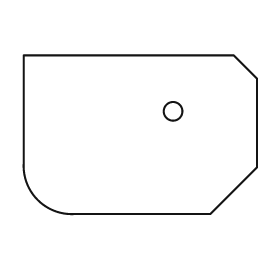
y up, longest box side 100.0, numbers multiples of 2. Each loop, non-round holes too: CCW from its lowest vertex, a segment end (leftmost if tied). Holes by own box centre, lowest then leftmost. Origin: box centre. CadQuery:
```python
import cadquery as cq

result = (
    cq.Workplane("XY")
    .moveTo(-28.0, -34.0)
    .lineTo(30.0, -34.0)
    .lineTo(50.0, -14.0)
    .lineTo(50.0, 24.0)
    .lineTo(40.0, 34.0)
    .lineTo(-50.0, 34.0)
    .lineTo(-50.0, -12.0)
    .threePointArc((-44.0, -28.0), (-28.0, -34.0))
    .close()
    .moveTo(14.0, 10.0)
    .circle(4.0)
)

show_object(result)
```